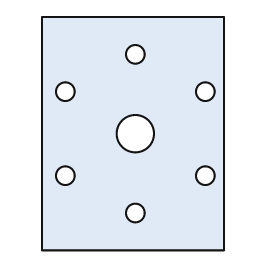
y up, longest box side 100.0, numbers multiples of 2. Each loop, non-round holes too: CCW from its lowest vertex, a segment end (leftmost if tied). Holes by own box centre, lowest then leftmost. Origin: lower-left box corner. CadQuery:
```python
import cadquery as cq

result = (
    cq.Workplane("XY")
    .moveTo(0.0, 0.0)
    .lineTo(78.0, 0.0)
    .lineTo(78.0, 100.0)
    .lineTo(0.0, 100.0)
    .close()
    .moveTo(40.0, 16.0)
    .circle(4.0)
    .moveTo(10.0, 32.0)
    .circle(4.0)
    .moveTo(70.0, 32.0)
    .circle(4.0)
    .moveTo(40.0, 50.0)
    .circle(8.0)
    .moveTo(10.0, 68.0)
    .circle(4.0)
    .moveTo(70.0, 68.0)
    .circle(4.0)
    .moveTo(40.0, 84.0)
    .circle(4.0)
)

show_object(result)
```